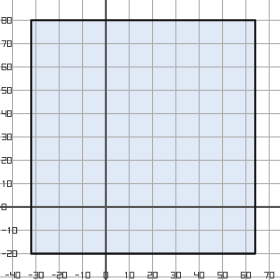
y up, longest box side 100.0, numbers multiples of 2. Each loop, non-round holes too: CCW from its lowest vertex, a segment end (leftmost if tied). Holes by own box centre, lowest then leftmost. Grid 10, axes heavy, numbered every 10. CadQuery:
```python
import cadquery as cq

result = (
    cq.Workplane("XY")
    .moveTo(-32.0, -20.0)
    .lineTo(64.0, -20.0)
    .lineTo(64.0, 80.0)
    .lineTo(-32.0, 80.0)
    .close()
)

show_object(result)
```